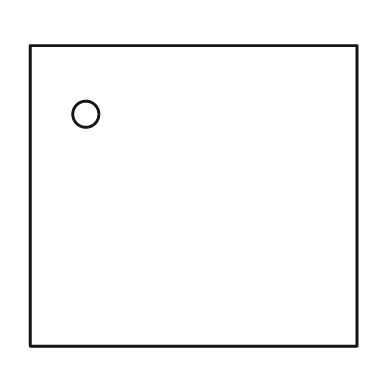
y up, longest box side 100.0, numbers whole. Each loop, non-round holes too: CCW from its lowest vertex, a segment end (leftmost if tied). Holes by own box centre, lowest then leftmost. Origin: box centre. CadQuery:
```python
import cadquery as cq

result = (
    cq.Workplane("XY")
    .moveTo(-50.0, -46.0)
    .lineTo(50.0, -46.0)
    .lineTo(50.0, 46.0)
    .lineTo(-50.0, 46.0)
    .close()
    .moveTo(-33.0, 25.0)
    .circle(4.0)
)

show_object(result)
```